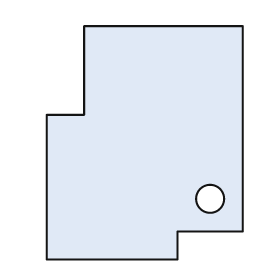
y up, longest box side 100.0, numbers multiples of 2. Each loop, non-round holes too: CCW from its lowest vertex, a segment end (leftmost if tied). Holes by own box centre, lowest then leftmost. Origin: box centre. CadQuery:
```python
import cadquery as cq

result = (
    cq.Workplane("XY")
    .moveTo(-42.0, -50.0)
    .lineTo(14.0, -50.0)
    .lineTo(14.0, -38.0)
    .lineTo(42.0, -38.0)
    .lineTo(42.0, 50.0)
    .lineTo(-26.0, 50.0)
    .lineTo(-26.0, 12.0)
    .lineTo(-42.0, 12.0)
    .close()
    .moveTo(28.0, -24.0)
    .circle(6.0)
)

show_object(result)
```